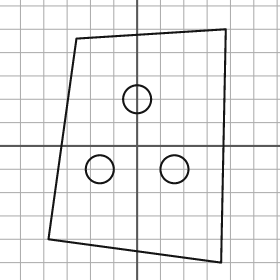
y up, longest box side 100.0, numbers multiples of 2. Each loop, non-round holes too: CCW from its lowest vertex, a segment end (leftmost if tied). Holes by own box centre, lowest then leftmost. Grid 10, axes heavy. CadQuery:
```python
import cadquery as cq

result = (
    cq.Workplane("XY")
    .moveTo(36.0, -50.0)
    .lineTo(38.0, 50.0)
    .lineTo(-26.0, 46.0)
    .lineTo(-38.0, -40.0)
    .close()
    .moveTo(-16.0, -10.0)
    .circle(6.0)
    .moveTo(16.0, -10.0)
    .circle(6.0)
    .moveTo(0.0, 20.0)
    .circle(6.0)
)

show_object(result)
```